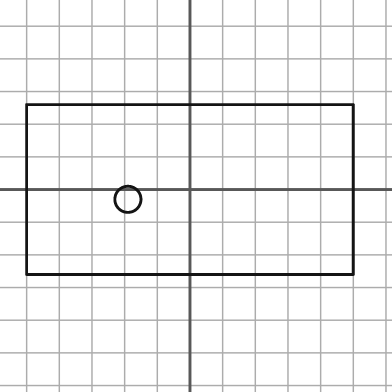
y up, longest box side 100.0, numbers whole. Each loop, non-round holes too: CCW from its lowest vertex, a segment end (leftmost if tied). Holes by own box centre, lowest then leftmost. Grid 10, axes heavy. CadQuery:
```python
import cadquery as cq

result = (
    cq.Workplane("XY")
    .moveTo(-50.0, -26.0)
    .lineTo(50.0, -26.0)
    .lineTo(50.0, 26.0)
    .lineTo(-50.0, 26.0)
    .close()
    .moveTo(-19.0, -3.0)
    .circle(4.0)
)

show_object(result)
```